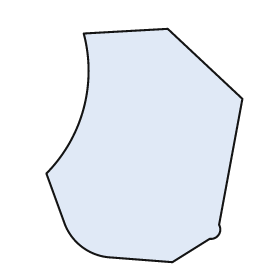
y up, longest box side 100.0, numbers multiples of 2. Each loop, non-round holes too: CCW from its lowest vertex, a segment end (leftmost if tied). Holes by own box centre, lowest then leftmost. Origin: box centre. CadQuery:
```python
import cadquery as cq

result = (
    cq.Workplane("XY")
    .moveTo(12.0, -50.0)
    .lineTo(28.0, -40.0)
    .threePointArc((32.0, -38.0), (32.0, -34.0))
    .lineTo(42.0, 20.0)
    .lineTo(10.0, 50.0)
    .lineTo(-26.0, 48.0)
    .threePointArc((-26.0, 16.0), (-42.0, -12.0))
    .lineTo(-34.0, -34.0)
    .threePointArc((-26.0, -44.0), (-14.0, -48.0))
    .close()
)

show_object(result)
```